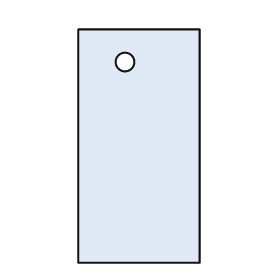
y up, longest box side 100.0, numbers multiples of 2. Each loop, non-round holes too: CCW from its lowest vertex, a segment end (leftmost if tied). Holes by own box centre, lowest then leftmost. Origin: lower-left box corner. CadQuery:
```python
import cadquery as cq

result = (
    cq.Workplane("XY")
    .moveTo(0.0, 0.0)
    .lineTo(52.0, 0.0)
    .lineTo(52.0, 100.0)
    .lineTo(0.0, 100.0)
    .close()
    .moveTo(20.0, 86.0)
    .circle(4.0)
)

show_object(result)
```